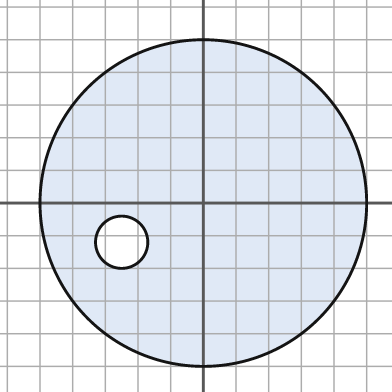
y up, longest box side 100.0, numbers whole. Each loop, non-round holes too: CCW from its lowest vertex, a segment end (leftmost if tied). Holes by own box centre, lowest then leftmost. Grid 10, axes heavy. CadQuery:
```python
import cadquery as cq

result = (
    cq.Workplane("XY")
    .moveTo(0.0, 0.0)
    .circle(50.0)
    .moveTo(-25.0, -12.0)
    .circle(8.0)
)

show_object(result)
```